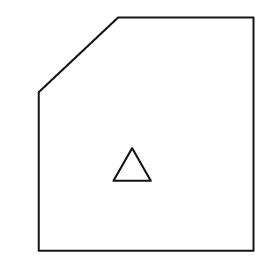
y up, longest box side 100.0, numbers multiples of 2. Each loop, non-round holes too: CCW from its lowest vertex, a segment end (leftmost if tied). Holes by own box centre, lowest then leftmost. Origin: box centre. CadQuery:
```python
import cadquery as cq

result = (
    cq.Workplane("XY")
    .moveTo(-46.0, -50.0)
    .lineTo(46.0, -50.0)
    .lineTo(46.0, 50.0)
    .lineTo(-12.0, 50.0)
    .lineTo(-46.0, 18.0)
    .close()
    .moveTo(-14.0, -20.0)
    .lineTo(2.0, -20.0)
    .lineTo(-6.0, -6.0)
    .close()
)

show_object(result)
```